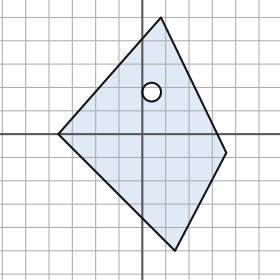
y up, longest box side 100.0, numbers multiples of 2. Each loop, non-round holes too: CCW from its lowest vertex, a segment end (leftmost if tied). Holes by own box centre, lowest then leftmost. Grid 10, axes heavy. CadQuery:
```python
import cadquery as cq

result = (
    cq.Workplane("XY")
    .moveTo(14.0, -50.0)
    .lineTo(36.0, -8.0)
    .lineTo(8.0, 50.0)
    .lineTo(-36.0, 0.0)
    .close()
    .moveTo(4.0, 18.0)
    .circle(4.0)
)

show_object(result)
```